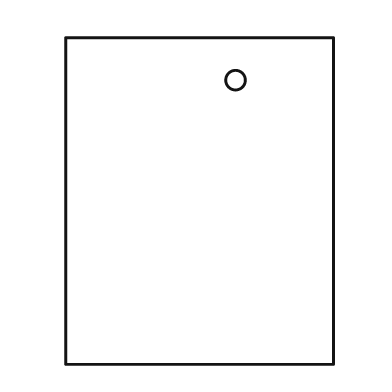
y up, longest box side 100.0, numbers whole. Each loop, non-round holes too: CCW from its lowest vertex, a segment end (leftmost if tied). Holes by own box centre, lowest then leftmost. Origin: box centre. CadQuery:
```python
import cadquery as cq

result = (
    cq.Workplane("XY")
    .moveTo(-41.0, -50.0)
    .lineTo(41.0, -50.0)
    .lineTo(41.0, 50.0)
    .lineTo(-41.0, 50.0)
    .close()
    .moveTo(11.0, 37.0)
    .circle(3.0)
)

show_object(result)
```